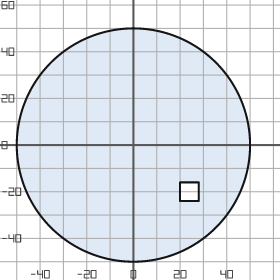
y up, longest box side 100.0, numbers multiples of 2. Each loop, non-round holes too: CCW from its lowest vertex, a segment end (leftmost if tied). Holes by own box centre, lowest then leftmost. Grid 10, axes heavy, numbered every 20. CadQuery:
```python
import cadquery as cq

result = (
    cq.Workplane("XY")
    .moveTo(0.0, 0.0)
    .circle(50.0)
    .moveTo(20.0, -24.0)
    .lineTo(28.0, -24.0)
    .lineTo(28.0, -16.0)
    .lineTo(20.0, -16.0)
    .close()
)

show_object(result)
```